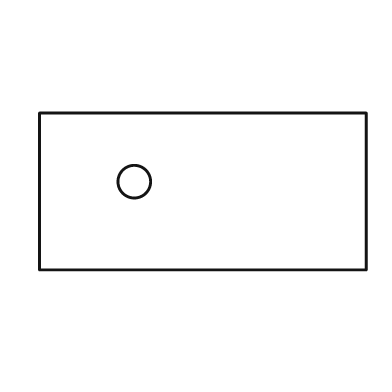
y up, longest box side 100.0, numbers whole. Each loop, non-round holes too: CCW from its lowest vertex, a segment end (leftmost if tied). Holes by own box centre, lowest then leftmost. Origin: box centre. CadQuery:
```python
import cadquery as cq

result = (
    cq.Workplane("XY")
    .moveTo(-50.0, -24.0)
    .lineTo(50.0, -24.0)
    .lineTo(50.0, 24.0)
    .lineTo(-50.0, 24.0)
    .close()
    .moveTo(-21.0, 3.0)
    .circle(5.0)
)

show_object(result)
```